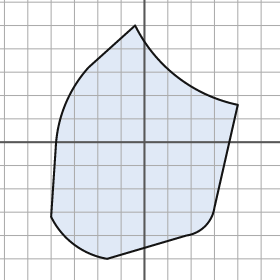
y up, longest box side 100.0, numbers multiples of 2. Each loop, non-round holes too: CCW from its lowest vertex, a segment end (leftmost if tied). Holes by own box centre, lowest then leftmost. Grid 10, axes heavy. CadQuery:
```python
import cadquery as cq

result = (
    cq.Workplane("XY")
    .moveTo(-16.0, -50.0)
    .lineTo(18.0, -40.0)
    .threePointArc((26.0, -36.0), (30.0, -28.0))
    .lineTo(40.0, 16.0)
    .threePointArc((14.0, 28.0), (-4.0, 50.0))
    .lineTo(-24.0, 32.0)
    .threePointArc((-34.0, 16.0), (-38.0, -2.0))
    .lineTo(-40.0, -32.0)
    .threePointArc((-30.0, -44.0), (-16.0, -50.0))
    .close()
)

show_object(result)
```